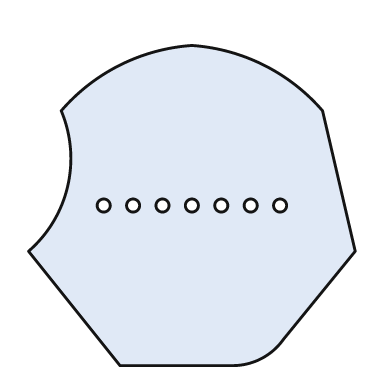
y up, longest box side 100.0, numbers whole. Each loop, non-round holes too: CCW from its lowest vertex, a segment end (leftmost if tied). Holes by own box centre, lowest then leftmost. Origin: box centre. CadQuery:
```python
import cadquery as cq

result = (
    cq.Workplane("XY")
    .moveTo(-22.0, -49.0)
    .lineTo(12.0, -49.0)
    .threePointArc((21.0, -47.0), (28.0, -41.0))
    .lineTo(50.0, -14.0)
    .lineTo(40.0, 29.0)
    .threePointArc((22.0, 43.0), (0.0, 49.0))
    .threePointArc((-22.0, 43.0), (-40.0, 29.0))
    .threePointArc((-38.0, 6.0), (-50.0, -14.0))
    .close()
    .moveTo(-27.0, 0.0)
    .circle(2.0)
    .moveTo(-18.0, 0.0)
    .circle(2.0)
    .moveTo(-9.0, 0.0)
    .circle(2.0)
    .moveTo(0.0, 0.0)
    .circle(2.0)
    .moveTo(9.0, 0.0)
    .circle(2.0)
    .moveTo(18.0, 0.0)
    .circle(2.0)
    .moveTo(27.0, 0.0)
    .circle(2.0)
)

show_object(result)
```